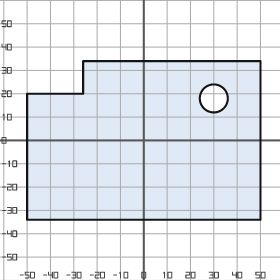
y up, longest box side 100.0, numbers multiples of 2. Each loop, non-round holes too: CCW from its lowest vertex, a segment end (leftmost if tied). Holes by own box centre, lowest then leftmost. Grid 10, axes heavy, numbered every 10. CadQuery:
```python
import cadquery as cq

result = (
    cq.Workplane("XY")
    .moveTo(-50.0, -34.0)
    .lineTo(50.0, -34.0)
    .lineTo(50.0, 34.0)
    .lineTo(-26.0, 34.0)
    .lineTo(-26.0, 20.0)
    .lineTo(-50.0, 20.0)
    .close()
    .moveTo(30.0, 18.0)
    .circle(6.0)
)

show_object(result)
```